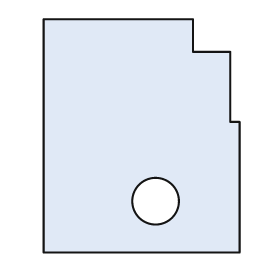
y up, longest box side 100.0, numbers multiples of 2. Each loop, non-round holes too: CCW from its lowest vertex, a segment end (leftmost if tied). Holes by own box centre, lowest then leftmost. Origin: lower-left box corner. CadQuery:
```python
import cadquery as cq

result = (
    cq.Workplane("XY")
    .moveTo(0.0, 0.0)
    .lineTo(84.0, 0.0)
    .lineTo(84.0, 56.0)
    .lineTo(80.0, 56.0)
    .lineTo(80.0, 86.0)
    .lineTo(64.0, 86.0)
    .lineTo(64.0, 100.0)
    .lineTo(0.0, 100.0)
    .close()
    .moveTo(48.0, 22.0)
    .circle(10.0)
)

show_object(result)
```